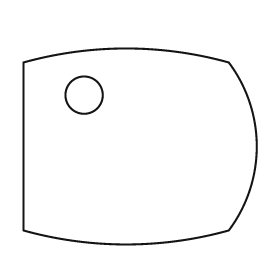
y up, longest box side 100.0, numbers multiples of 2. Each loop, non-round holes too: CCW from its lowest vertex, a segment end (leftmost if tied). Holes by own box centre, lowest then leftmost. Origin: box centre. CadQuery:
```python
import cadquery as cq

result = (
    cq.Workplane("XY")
    .moveTo(-50.0, -36.0)
    .threePointArc((-6.0, -42.0), (38.0, -36.0))
    .threePointArc((50.0, 0.0), (38.0, 36.0))
    .threePointArc((-6.0, 42.0), (-50.0, 36.0))
    .close()
    .moveTo(-24.0, 22.0)
    .circle(8.0)
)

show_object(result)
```